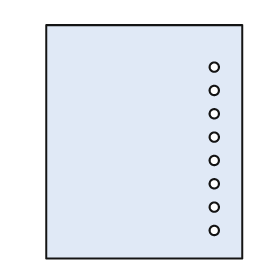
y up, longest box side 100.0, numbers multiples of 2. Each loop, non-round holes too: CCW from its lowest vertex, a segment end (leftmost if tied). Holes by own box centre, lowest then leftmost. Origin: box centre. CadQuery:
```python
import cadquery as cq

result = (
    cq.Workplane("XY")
    .moveTo(-42.0, -50.0)
    .lineTo(42.0, -50.0)
    .lineTo(42.0, 50.0)
    .lineTo(-42.0, 50.0)
    .close()
    .moveTo(30.0, -38.0)
    .circle(2.0)
    .moveTo(30.0, -28.0)
    .circle(2.0)
    .moveTo(30.0, -18.0)
    .circle(2.0)
    .moveTo(30.0, -8.0)
    .circle(2.0)
    .moveTo(30.0, 2.0)
    .circle(2.0)
    .moveTo(30.0, 12.0)
    .circle(2.0)
    .moveTo(30.0, 22.0)
    .circle(2.0)
    .moveTo(30.0, 32.0)
    .circle(2.0)
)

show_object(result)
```